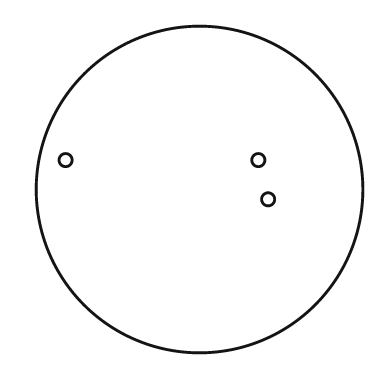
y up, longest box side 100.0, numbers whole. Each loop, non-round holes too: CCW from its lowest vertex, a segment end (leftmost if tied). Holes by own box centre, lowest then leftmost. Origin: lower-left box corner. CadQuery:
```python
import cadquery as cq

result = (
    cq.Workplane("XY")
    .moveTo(50.0, 50.0)
    .circle(50.0)
    .moveTo(71.0, 47.0)
    .circle(2.0)
    .moveTo(9.0, 59.0)
    .circle(2.0)
    .moveTo(68.0, 59.0)
    .circle(2.0)
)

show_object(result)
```